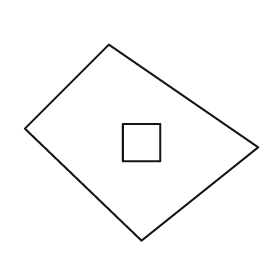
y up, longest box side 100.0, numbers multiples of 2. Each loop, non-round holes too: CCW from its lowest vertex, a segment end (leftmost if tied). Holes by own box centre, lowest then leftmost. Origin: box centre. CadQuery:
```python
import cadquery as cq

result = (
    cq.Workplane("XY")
    .moveTo(0.0, -42.0)
    .lineTo(50.0, -2.0)
    .lineTo(-14.0, 42.0)
    .lineTo(-50.0, 6.0)
    .close()
    .moveTo(-8.0, -8.0)
    .lineTo(8.0, -8.0)
    .lineTo(8.0, 8.0)
    .lineTo(-8.0, 8.0)
    .close()
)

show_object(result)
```